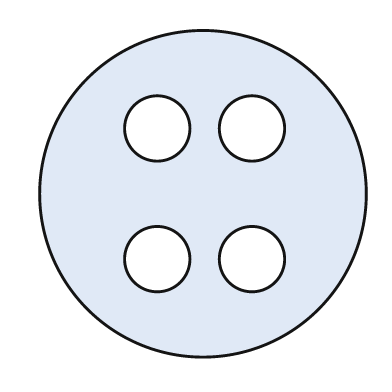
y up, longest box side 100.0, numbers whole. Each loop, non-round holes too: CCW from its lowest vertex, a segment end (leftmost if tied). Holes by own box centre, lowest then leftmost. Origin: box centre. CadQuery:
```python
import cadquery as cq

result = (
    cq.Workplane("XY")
    .moveTo(0.0, 0.0)
    .circle(50.0)
    .moveTo(-14.0, -20.0)
    .circle(10.0)
    .moveTo(15.0, -20.0)
    .circle(10.0)
    .moveTo(-14.0, 20.0)
    .circle(10.0)
    .moveTo(15.0, 20.0)
    .circle(10.0)
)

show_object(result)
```